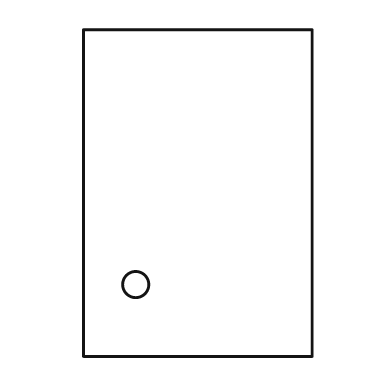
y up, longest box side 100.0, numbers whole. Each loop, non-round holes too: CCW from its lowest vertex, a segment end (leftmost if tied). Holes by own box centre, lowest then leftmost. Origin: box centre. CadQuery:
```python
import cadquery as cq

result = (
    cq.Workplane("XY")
    .moveTo(-35.0, -50.0)
    .lineTo(35.0, -50.0)
    .lineTo(35.0, 50.0)
    .lineTo(-35.0, 50.0)
    .close()
    .moveTo(-19.0, -28.0)
    .circle(4.0)
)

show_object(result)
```